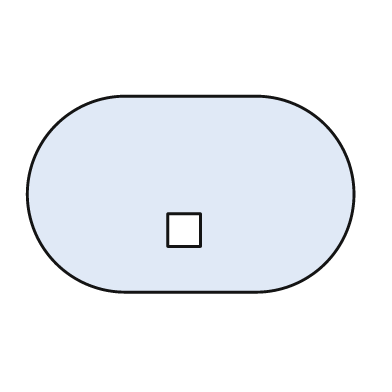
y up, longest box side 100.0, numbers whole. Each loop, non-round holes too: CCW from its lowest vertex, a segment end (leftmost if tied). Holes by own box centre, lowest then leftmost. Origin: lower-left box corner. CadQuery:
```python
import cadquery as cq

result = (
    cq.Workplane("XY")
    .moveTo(30.0, 0.0)
    .lineTo(70.0, 0.0)
    .threePointArc((100.0, 30.0), (70.0, 60.0))
    .lineTo(30.0, 60.0)
    .threePointArc((0.0, 30.0), (30.0, 0.0))
    .close()
    .moveTo(43.0, 14.0)
    .lineTo(53.0, 14.0)
    .lineTo(53.0, 24.0)
    .lineTo(43.0, 24.0)
    .close()
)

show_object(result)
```